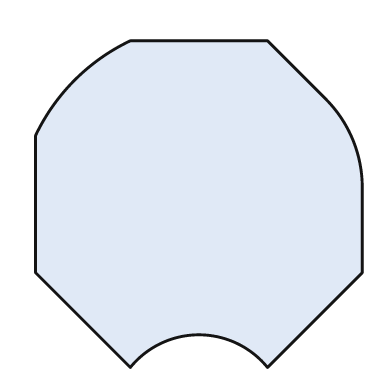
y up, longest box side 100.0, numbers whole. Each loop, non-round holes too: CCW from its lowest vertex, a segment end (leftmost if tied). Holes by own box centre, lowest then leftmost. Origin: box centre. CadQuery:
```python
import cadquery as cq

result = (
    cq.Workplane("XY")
    .moveTo(-21.0, -50.0)
    .threePointArc((0.0, -40.0), (21.0, -50.0))
    .lineTo(50.0, -21.0)
    .lineTo(50.0, 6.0)
    .threePointArc((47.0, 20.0), (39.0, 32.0))
    .lineTo(21.0, 50.0)
    .lineTo(-21.0, 50.0)
    .threePointArc((-38.0, 38.0), (-50.0, 21.0))
    .lineTo(-50.0, -21.0)
    .close()
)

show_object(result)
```